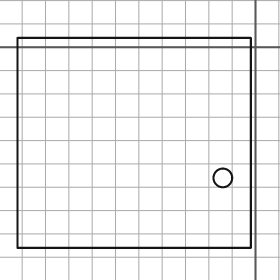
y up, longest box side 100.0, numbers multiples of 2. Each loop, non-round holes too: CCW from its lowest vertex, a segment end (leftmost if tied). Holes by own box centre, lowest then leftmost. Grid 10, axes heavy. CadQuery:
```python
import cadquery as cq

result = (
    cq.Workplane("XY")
    .moveTo(-102.0, -86.0)
    .lineTo(-2.0, -86.0)
    .lineTo(-2.0, 4.0)
    .lineTo(-102.0, 4.0)
    .close()
    .moveTo(-14.0, -56.0)
    .circle(4.0)
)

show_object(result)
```